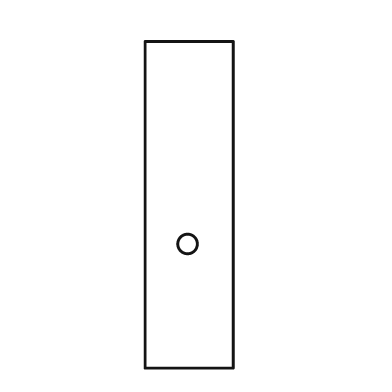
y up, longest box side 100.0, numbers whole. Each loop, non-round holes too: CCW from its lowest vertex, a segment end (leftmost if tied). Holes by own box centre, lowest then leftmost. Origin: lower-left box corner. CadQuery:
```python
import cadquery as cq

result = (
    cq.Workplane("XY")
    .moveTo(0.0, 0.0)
    .lineTo(27.0, 0.0)
    .lineTo(27.0, 100.0)
    .lineTo(0.0, 100.0)
    .close()
    .moveTo(13.0, 38.0)
    .circle(3.0)
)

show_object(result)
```